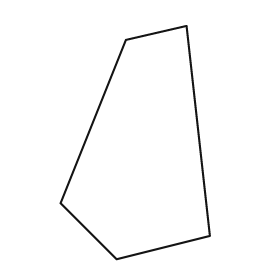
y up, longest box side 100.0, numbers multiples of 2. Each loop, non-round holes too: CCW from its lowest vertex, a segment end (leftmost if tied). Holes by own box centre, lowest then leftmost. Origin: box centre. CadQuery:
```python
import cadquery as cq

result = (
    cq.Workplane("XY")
    .moveTo(-8.0, -50.0)
    .lineTo(32.0, -40.0)
    .lineTo(22.0, 50.0)
    .lineTo(-4.0, 44.0)
    .lineTo(-32.0, -26.0)
    .close()
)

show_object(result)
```